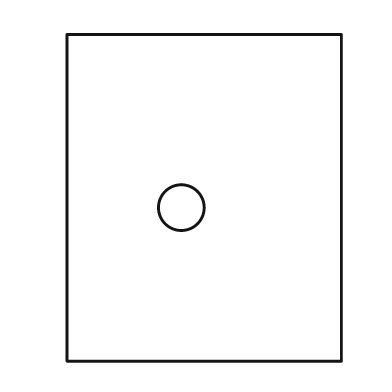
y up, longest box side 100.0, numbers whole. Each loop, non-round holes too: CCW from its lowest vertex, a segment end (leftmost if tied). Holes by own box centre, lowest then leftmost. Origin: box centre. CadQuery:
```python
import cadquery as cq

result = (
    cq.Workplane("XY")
    .moveTo(-42.0, -50.0)
    .lineTo(42.0, -50.0)
    .lineTo(42.0, 50.0)
    .lineTo(-42.0, 50.0)
    .close()
    .moveTo(-7.0, -3.0)
    .circle(7.0)
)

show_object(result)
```